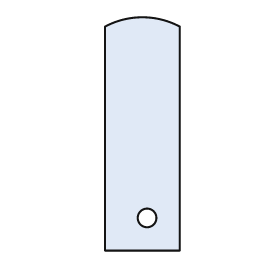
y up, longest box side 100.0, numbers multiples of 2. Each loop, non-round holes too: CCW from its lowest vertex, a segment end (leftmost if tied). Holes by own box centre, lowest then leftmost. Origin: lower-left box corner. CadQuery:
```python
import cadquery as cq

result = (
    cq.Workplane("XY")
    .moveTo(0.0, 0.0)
    .lineTo(32.0, 0.0)
    .lineTo(32.0, 96.0)
    .threePointArc((16.0, 100.0), (0.0, 96.0))
    .close()
    .moveTo(18.0, 14.0)
    .circle(4.0)
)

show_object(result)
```